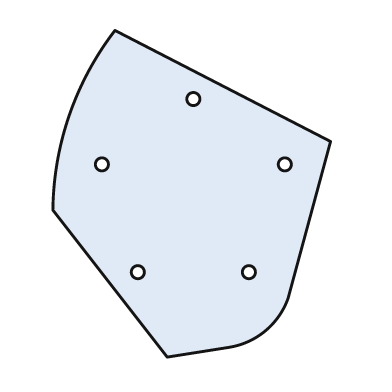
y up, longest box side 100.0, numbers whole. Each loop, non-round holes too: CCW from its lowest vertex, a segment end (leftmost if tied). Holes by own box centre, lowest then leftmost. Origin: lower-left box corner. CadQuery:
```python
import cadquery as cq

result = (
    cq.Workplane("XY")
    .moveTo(35.0, 0.0)
    .lineTo(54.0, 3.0)
    .threePointArc((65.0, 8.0), (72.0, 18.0))
    .lineTo(85.0, 66.0)
    .lineTo(19.0, 100.0)
    .threePointArc((5.0, 74.0), (0.0, 45.0))
    .close()
    .moveTo(26.0, 26.0)
    .circle(2.0)
    .moveTo(60.0, 26.0)
    .circle(2.0)
    .moveTo(15.0, 59.0)
    .circle(2.0)
    .moveTo(71.0, 59.0)
    .circle(2.0)
    .moveTo(43.0, 79.0)
    .circle(2.0)
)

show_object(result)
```